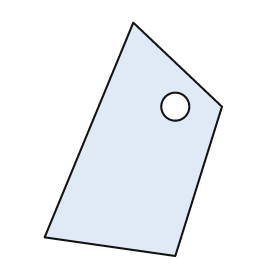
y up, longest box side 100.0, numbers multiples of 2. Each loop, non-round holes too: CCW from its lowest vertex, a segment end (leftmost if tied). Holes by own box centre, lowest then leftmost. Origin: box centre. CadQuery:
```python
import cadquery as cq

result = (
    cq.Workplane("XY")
    .moveTo(18.0, -50.0)
    .lineTo(38.0, 14.0)
    .lineTo(0.0, 50.0)
    .lineTo(-38.0, -42.0)
    .close()
    .moveTo(18.0, 14.0)
    .circle(6.0)
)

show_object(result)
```